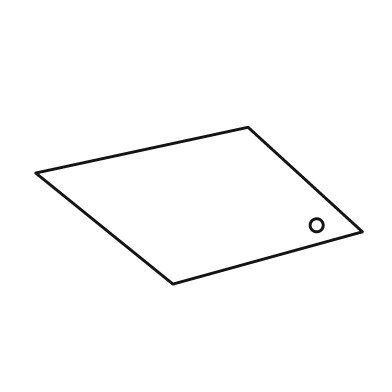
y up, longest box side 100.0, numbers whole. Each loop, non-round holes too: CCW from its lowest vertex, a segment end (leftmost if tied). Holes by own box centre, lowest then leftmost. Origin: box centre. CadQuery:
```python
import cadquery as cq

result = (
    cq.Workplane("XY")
    .moveTo(-8.0, -24.0)
    .lineTo(50.0, -8.0)
    .lineTo(15.0, 24.0)
    .lineTo(-50.0, 10.0)
    .close()
    .moveTo(36.0, -6.0)
    .circle(2.0)
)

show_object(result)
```